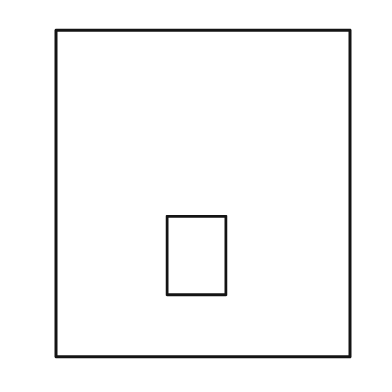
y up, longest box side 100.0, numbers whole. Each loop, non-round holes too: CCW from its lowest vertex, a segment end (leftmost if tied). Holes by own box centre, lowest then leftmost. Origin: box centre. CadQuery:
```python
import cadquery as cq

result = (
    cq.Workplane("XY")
    .moveTo(-45.0, -50.0)
    .lineTo(45.0, -50.0)
    .lineTo(45.0, 50.0)
    .lineTo(-45.0, 50.0)
    .close()
    .moveTo(-11.0, -31.0)
    .lineTo(7.0, -31.0)
    .lineTo(7.0, -7.0)
    .lineTo(-11.0, -7.0)
    .close()
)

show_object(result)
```